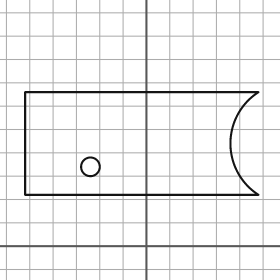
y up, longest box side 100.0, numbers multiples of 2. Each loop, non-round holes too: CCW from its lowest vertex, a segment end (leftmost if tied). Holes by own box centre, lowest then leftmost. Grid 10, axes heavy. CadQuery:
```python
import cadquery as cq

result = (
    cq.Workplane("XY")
    .moveTo(-52.0, 22.0)
    .lineTo(48.0, 22.0)
    .threePointArc((36.0, 44.0), (48.0, 66.0))
    .lineTo(-52.0, 66.0)
    .close()
    .moveTo(-24.0, 34.0)
    .circle(4.0)
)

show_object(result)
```